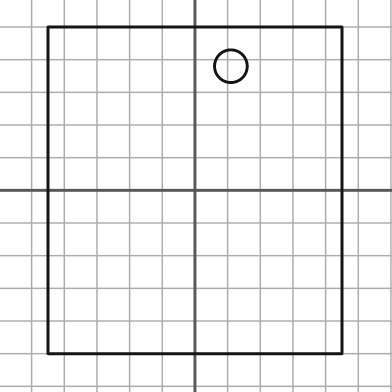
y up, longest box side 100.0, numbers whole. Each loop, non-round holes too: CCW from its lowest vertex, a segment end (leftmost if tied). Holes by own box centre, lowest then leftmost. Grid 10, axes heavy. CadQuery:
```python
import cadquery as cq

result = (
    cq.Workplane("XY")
    .moveTo(-45.0, -50.0)
    .lineTo(45.0, -50.0)
    .lineTo(45.0, 50.0)
    .lineTo(-45.0, 50.0)
    .close()
    .moveTo(11.0, 38.0)
    .circle(5.0)
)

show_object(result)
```